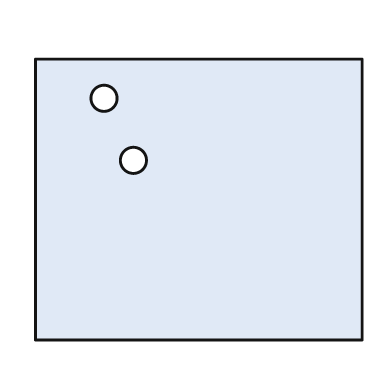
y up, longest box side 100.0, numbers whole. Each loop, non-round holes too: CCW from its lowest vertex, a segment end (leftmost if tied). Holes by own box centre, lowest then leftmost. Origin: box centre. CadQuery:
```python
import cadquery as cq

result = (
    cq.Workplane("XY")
    .moveTo(-50.0, -43.0)
    .lineTo(50.0, -43.0)
    .lineTo(50.0, 43.0)
    .lineTo(-50.0, 43.0)
    .close()
    .moveTo(-20.0, 12.0)
    .circle(4.0)
    .moveTo(-29.0, 31.0)
    .circle(4.0)
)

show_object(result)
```